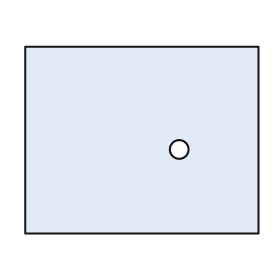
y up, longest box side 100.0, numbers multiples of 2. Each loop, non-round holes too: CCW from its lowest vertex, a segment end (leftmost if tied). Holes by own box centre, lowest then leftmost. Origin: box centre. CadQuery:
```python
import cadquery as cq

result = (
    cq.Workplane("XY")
    .moveTo(-50.0, -40.0)
    .lineTo(50.0, -40.0)
    .lineTo(50.0, 40.0)
    .lineTo(-50.0, 40.0)
    .close()
    .moveTo(16.0, -4.0)
    .circle(4.0)
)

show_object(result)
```